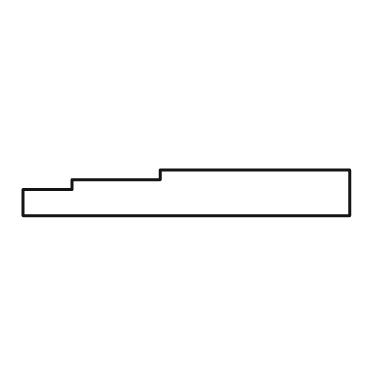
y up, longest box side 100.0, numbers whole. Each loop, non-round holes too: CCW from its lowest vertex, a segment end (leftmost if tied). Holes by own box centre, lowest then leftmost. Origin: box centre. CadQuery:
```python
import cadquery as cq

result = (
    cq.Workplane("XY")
    .moveTo(-50.0, -7.0)
    .lineTo(50.0, -7.0)
    .lineTo(50.0, 7.0)
    .lineTo(-8.0, 7.0)
    .lineTo(-8.0, 4.0)
    .lineTo(-35.0, 4.0)
    .lineTo(-35.0, 1.0)
    .lineTo(-50.0, 1.0)
    .close()
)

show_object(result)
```